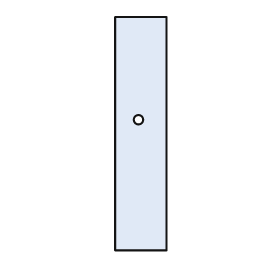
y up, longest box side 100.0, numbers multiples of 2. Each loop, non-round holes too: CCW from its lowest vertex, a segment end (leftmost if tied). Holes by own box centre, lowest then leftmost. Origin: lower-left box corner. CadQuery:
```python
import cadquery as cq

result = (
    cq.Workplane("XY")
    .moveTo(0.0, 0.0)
    .lineTo(22.0, 0.0)
    .lineTo(22.0, 100.0)
    .lineTo(0.0, 100.0)
    .close()
    .moveTo(10.0, 56.0)
    .circle(2.0)
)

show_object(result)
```